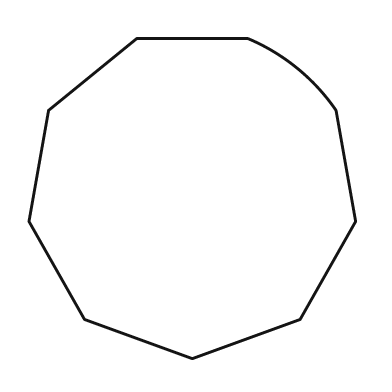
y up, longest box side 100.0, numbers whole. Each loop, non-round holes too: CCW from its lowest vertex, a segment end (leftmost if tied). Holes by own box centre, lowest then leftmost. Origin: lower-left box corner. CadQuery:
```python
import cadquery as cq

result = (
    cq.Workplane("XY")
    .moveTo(50.0, 0.0)
    .lineTo(83.0, 12.0)
    .lineTo(100.0, 42.0)
    .lineTo(94.0, 76.0)
    .threePointArc((82.0, 89.0), (67.0, 98.0))
    .lineTo(33.0, 98.0)
    .lineTo(6.0, 76.0)
    .lineTo(0.0, 42.0)
    .lineTo(17.0, 12.0)
    .close()
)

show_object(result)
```